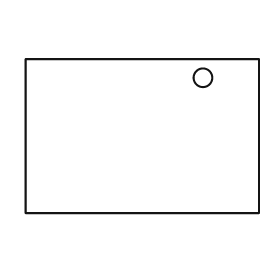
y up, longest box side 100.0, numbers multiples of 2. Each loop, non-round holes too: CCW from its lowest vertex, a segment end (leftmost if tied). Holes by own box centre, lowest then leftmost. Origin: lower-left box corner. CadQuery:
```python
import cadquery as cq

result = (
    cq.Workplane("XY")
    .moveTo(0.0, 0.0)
    .lineTo(100.0, 0.0)
    .lineTo(100.0, 66.0)
    .lineTo(0.0, 66.0)
    .close()
    .moveTo(76.0, 58.0)
    .circle(4.0)
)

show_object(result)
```